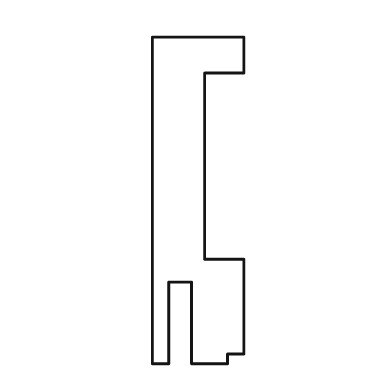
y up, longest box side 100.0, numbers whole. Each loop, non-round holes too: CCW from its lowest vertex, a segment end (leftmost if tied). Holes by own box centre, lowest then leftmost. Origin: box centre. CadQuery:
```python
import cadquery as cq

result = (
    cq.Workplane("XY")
    .moveTo(-14.0, -50.0)
    .lineTo(-9.0, -50.0)
    .lineTo(-9.0, -25.0)
    .lineTo(-2.0, -25.0)
    .lineTo(-2.0, -50.0)
    .lineTo(9.0, -50.0)
    .lineTo(9.0, -47.0)
    .lineTo(14.0, -47.0)
    .lineTo(14.0, -18.0)
    .lineTo(2.0, -18.0)
    .lineTo(2.0, 39.0)
    .lineTo(14.0, 39.0)
    .lineTo(14.0, 50.0)
    .lineTo(-14.0, 50.0)
    .close()
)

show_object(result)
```